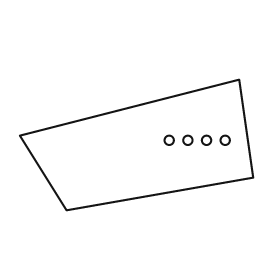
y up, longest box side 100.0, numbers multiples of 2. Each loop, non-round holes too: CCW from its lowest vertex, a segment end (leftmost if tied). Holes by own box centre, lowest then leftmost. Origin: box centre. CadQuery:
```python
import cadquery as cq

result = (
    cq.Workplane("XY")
    .moveTo(-30.0, -28.0)
    .lineTo(50.0, -14.0)
    .lineTo(44.0, 28.0)
    .lineTo(-50.0, 4.0)
    .close()
    .moveTo(14.0, 2.0)
    .circle(2.0)
    .moveTo(22.0, 2.0)
    .circle(2.0)
    .moveTo(30.0, 2.0)
    .circle(2.0)
    .moveTo(38.0, 2.0)
    .circle(2.0)
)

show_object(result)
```